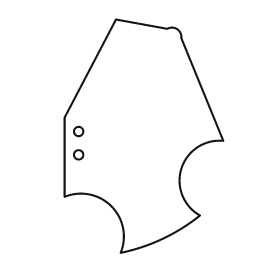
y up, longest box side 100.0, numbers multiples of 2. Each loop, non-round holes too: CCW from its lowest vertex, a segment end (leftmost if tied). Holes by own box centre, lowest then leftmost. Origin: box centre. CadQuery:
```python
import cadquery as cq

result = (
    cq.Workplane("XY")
    .moveTo(-10.0, -50.0)
    .threePointArc((8.0, -44.0), (24.0, -34.0))
    .threePointArc((16.0, -14.0), (34.0, -2.0))
    .lineTo(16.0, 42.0)
    .threePointArc((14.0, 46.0), (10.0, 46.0))
    .lineTo(-12.0, 50.0)
    .lineTo(-34.0, 8.0)
    .lineTo(-34.0, -26.0)
    .threePointArc((-14.0, -30.0), (-10.0, -50.0))
    .close()
    .moveTo(-28.0, -8.0)
    .circle(2.0)
    .moveTo(-28.0, 2.0)
    .circle(2.0)
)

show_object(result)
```